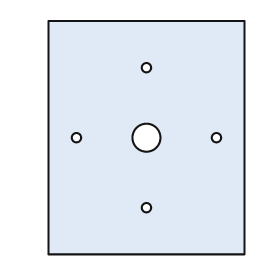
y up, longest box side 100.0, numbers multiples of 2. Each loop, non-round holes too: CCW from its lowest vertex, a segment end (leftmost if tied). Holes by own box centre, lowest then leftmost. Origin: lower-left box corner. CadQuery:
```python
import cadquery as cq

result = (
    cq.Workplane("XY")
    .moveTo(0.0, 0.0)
    .lineTo(84.0, 0.0)
    .lineTo(84.0, 100.0)
    .lineTo(0.0, 100.0)
    .close()
    .moveTo(42.0, 20.0)
    .circle(2.0)
    .moveTo(12.0, 50.0)
    .circle(2.0)
    .moveTo(42.0, 50.0)
    .circle(6.0)
    .moveTo(72.0, 50.0)
    .circle(2.0)
    .moveTo(42.0, 80.0)
    .circle(2.0)
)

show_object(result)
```